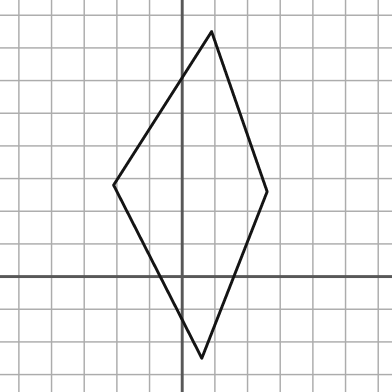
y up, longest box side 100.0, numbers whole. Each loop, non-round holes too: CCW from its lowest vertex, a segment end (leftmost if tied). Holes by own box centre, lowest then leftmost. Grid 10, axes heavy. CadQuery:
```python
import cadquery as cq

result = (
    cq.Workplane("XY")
    .moveTo(6.0, -25.0)
    .lineTo(26.0, 26.0)
    .lineTo(9.0, 75.0)
    .lineTo(-21.0, 28.0)
    .close()
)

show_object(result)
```